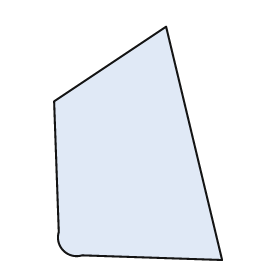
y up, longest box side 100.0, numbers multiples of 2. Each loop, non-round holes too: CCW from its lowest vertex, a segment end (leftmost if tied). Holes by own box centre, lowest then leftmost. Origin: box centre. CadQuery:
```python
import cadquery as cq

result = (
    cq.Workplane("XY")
    .moveTo(36.0, -50.0)
    .lineTo(12.0, 50.0)
    .lineTo(-36.0, 18.0)
    .lineTo(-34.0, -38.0)
    .threePointArc((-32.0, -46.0), (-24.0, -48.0))
    .close()
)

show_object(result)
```